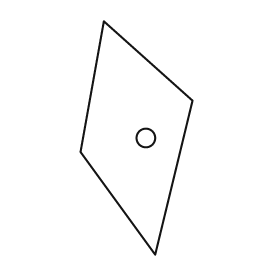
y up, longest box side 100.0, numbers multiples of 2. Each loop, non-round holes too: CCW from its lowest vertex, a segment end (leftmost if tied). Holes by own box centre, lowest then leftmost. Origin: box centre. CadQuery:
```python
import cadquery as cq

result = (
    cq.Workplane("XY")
    .moveTo(8.0, -50.0)
    .lineTo(24.0, 16.0)
    .lineTo(-14.0, 50.0)
    .lineTo(-24.0, -6.0)
    .close()
    .moveTo(4.0, 0.0)
    .circle(4.0)
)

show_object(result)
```